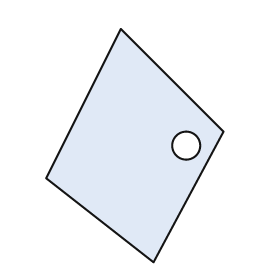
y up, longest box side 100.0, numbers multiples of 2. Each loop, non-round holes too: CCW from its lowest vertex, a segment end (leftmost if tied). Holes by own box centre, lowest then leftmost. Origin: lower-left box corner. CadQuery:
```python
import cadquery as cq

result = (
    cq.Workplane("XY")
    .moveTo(46.0, 0.0)
    .lineTo(76.0, 56.0)
    .lineTo(32.0, 100.0)
    .lineTo(0.0, 36.0)
    .close()
    .moveTo(60.0, 50.0)
    .circle(6.0)
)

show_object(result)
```